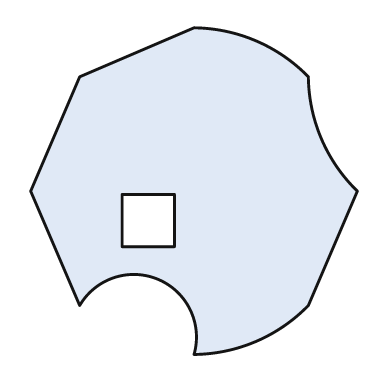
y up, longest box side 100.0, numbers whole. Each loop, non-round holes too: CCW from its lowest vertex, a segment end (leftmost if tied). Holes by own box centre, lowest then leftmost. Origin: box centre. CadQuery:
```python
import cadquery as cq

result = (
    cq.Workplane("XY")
    .moveTo(0.0, -50.0)
    .threePointArc((19.0, -46.0), (35.0, -35.0))
    .lineTo(50.0, 0.0)
    .threePointArc((39.0, 16.0), (35.0, 35.0))
    .threePointArc((19.0, 46.0), (0.0, 50.0))
    .lineTo(-35.0, 35.0)
    .lineTo(-50.0, 0.0)
    .lineTo(-35.0, -35.0)
    .threePointArc((-11.0, -27.0), (0.0, -50.0))
    .close()
    .moveTo(-22.0, -17.0)
    .lineTo(-6.0, -17.0)
    .lineTo(-6.0, -1.0)
    .lineTo(-22.0, -1.0)
    .close()
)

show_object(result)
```